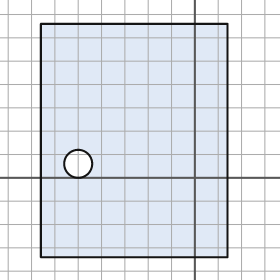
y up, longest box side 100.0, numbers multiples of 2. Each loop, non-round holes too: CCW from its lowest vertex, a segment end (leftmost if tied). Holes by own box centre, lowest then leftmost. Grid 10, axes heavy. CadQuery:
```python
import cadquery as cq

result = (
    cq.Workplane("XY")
    .moveTo(-66.0, -34.0)
    .lineTo(14.0, -34.0)
    .lineTo(14.0, 66.0)
    .lineTo(-66.0, 66.0)
    .close()
    .moveTo(-50.0, 6.0)
    .circle(6.0)
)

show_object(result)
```